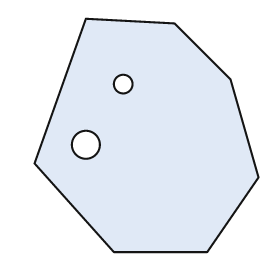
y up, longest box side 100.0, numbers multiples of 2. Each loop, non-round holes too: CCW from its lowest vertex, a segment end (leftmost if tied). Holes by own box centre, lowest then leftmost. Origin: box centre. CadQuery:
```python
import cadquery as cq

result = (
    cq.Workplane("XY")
    .moveTo(-14.0, -50.0)
    .lineTo(26.0, -50.0)
    .lineTo(48.0, -18.0)
    .lineTo(36.0, 24.0)
    .lineTo(12.0, 48.0)
    .lineTo(-26.0, 50.0)
    .lineTo(-48.0, -12.0)
    .close()
    .moveTo(-26.0, -4.0)
    .circle(6.0)
    .moveTo(-10.0, 22.0)
    .circle(4.0)
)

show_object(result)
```